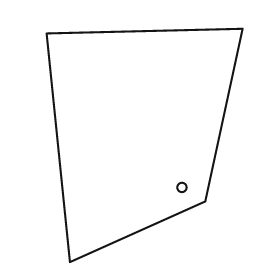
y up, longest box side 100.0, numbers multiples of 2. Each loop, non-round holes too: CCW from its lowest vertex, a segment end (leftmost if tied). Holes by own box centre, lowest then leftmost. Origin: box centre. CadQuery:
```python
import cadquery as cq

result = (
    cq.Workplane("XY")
    .moveTo(-32.0, -50.0)
    .lineTo(26.0, -24.0)
    .lineTo(42.0, 50.0)
    .lineTo(-42.0, 48.0)
    .close()
    .moveTo(16.0, -18.0)
    .circle(2.0)
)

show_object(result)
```